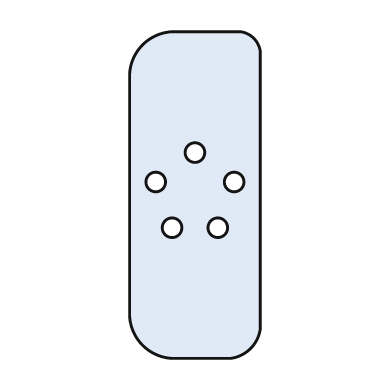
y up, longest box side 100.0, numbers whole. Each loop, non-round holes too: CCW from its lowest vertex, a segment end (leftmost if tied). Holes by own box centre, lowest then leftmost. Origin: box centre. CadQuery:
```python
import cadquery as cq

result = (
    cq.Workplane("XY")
    .moveTo(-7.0, -50.0)
    .lineTo(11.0, -50.0)
    .threePointArc((17.0, -47.0), (20.0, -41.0))
    .lineTo(20.0, 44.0)
    .threePointArc((18.0, 48.0), (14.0, 50.0))
    .lineTo(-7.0, 50.0)
    .threePointArc((-16.0, 46.0), (-20.0, 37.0))
    .lineTo(-20.0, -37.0)
    .threePointArc((-16.0, -46.0), (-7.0, -50.0))
    .close()
    .moveTo(-7.0, -10.0)
    .circle(3.0)
    .moveTo(7.0, -10.0)
    .circle(3.0)
    .moveTo(-12.0, 4.0)
    .circle(3.0)
    .moveTo(12.0, 4.0)
    .circle(3.0)
    .moveTo(0.0, 13.0)
    .circle(3.0)
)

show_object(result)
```